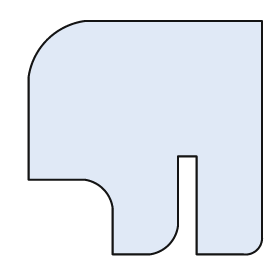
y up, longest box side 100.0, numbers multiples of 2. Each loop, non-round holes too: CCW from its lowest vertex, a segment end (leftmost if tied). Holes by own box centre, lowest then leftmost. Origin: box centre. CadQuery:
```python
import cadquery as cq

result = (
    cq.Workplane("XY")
    .moveTo(-14.0, -50.0)
    .lineTo(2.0, -50.0)
    .threePointArc((10.0, -46.0), (14.0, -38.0))
    .lineTo(14.0, -8.0)
    .lineTo(22.0, -8.0)
    .lineTo(22.0, -50.0)
    .lineTo(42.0, -50.0)
    .threePointArc((48.0, -48.0), (50.0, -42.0))
    .lineTo(50.0, 50.0)
    .lineTo(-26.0, 50.0)
    .threePointArc((-42.0, 42.0), (-50.0, 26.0))
    .lineTo(-50.0, -18.0)
    .lineTo(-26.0, -18.0)
    .threePointArc((-18.0, -22.0), (-14.0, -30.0))
    .close()
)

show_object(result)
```